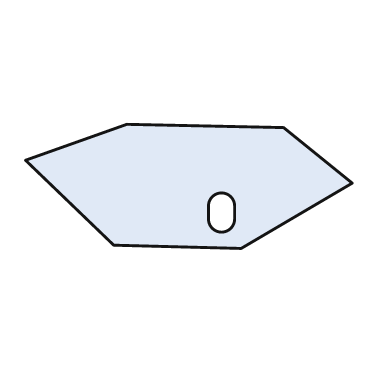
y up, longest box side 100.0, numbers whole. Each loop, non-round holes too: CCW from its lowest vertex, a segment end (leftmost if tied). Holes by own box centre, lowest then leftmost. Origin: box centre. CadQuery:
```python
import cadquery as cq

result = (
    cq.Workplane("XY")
    .moveTo(16.0, -19.0)
    .lineTo(50.0, 1.0)
    .lineTo(29.0, 18.0)
    .lineTo(-19.0, 19.0)
    .lineTo(-50.0, 8.0)
    .lineTo(-23.0, -18.0)
    .close()
    .moveTo(6.0, -10.0)
    .threePointArc((10.0, -14.0), (14.0, -10.0))
    .lineTo(14.0, -6.0)
    .threePointArc((10.0, -2.0), (6.0, -6.0))
    .close()
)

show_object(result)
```